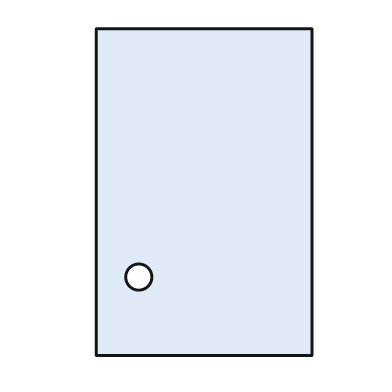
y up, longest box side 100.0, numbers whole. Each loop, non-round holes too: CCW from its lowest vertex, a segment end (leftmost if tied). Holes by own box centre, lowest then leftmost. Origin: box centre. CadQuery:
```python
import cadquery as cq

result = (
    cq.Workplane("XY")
    .moveTo(-33.0, -50.0)
    .lineTo(33.0, -50.0)
    .lineTo(33.0, 50.0)
    .lineTo(-33.0, 50.0)
    .close()
    .moveTo(-20.0, -26.0)
    .circle(4.0)
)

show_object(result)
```